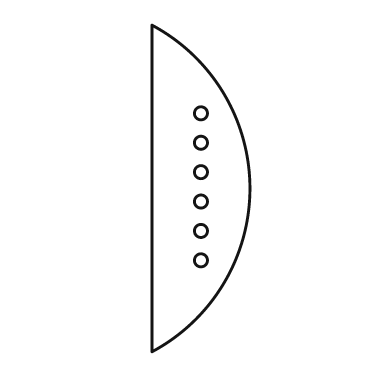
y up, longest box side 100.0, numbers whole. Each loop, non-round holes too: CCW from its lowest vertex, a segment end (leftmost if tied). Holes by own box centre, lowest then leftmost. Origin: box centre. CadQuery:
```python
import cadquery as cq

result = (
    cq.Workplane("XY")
    .moveTo(-15.0, -50.0)
    .threePointArc((15.0, 0.0), (-15.0, 50.0))
    .close()
    .moveTo(0.0, -22.0)
    .circle(2.0)
    .moveTo(0.0, -13.0)
    .circle(2.0)
    .moveTo(0.0, -4.0)
    .circle(2.0)
    .moveTo(0.0, 5.0)
    .circle(2.0)
    .moveTo(0.0, 14.0)
    .circle(2.0)
    .moveTo(0.0, 23.0)
    .circle(2.0)
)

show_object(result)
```